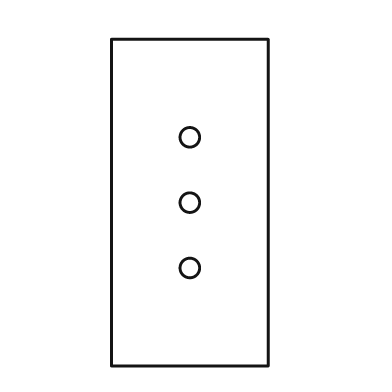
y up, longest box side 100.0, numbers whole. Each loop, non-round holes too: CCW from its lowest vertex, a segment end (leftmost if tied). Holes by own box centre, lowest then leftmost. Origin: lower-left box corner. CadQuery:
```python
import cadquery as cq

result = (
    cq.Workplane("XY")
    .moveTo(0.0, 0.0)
    .lineTo(48.0, 0.0)
    .lineTo(48.0, 100.0)
    .lineTo(0.0, 100.0)
    .close()
    .moveTo(24.0, 30.0)
    .circle(3.0)
    .moveTo(24.0, 50.0)
    .circle(3.0)
    .moveTo(24.0, 70.0)
    .circle(3.0)
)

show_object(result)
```